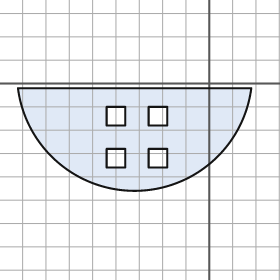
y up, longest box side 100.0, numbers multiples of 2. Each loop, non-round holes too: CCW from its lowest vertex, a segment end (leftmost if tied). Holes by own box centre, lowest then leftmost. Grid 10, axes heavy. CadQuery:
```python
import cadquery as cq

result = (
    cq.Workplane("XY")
    .moveTo(-82.0, -2.0)
    .threePointArc((-32.0, -46.0), (18.0, -2.0))
    .close()
    .moveTo(-44.0, -36.0)
    .lineTo(-36.0, -36.0)
    .lineTo(-36.0, -28.0)
    .lineTo(-44.0, -28.0)
    .close()
    .moveTo(-26.0, -36.0)
    .lineTo(-18.0, -36.0)
    .lineTo(-18.0, -28.0)
    .lineTo(-26.0, -28.0)
    .close()
    .moveTo(-44.0, -18.0)
    .lineTo(-36.0, -18.0)
    .lineTo(-36.0, -10.0)
    .lineTo(-44.0, -10.0)
    .close()
    .moveTo(-26.0, -18.0)
    .lineTo(-18.0, -18.0)
    .lineTo(-18.0, -10.0)
    .lineTo(-26.0, -10.0)
    .close()
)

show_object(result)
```